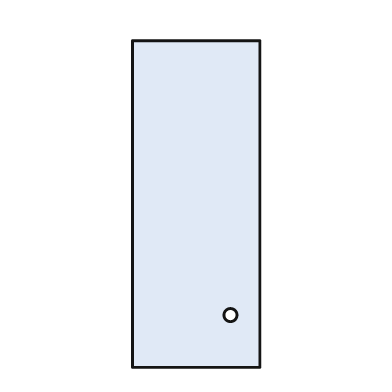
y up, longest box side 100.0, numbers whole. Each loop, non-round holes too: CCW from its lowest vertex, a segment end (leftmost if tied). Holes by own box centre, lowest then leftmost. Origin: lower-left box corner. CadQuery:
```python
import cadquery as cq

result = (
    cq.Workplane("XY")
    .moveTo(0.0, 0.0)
    .lineTo(39.0, 0.0)
    .lineTo(39.0, 100.0)
    .lineTo(0.0, 100.0)
    .close()
    .moveTo(30.0, 16.0)
    .circle(2.0)
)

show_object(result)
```